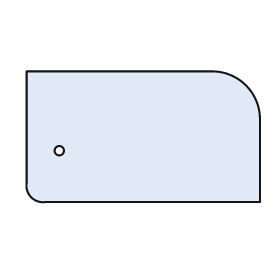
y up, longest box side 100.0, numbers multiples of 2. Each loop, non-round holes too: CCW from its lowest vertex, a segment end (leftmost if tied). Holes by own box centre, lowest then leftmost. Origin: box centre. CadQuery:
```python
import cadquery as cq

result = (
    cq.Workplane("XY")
    .moveTo(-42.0, -28.0)
    .lineTo(50.0, -28.0)
    .lineTo(50.0, 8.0)
    .threePointArc((44.0, 22.0), (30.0, 28.0))
    .lineTo(-50.0, 28.0)
    .lineTo(-50.0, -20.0)
    .threePointArc((-48.0, -26.0), (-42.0, -28.0))
    .close()
    .moveTo(-36.0, -6.0)
    .circle(2.0)
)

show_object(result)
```